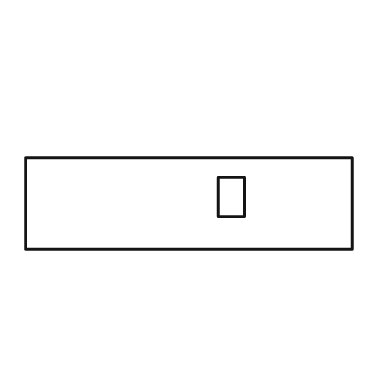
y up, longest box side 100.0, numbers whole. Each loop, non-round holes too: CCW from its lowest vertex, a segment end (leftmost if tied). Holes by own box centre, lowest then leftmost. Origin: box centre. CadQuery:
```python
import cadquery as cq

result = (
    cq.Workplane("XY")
    .moveTo(-50.0, -14.0)
    .lineTo(50.0, -14.0)
    .lineTo(50.0, 14.0)
    .lineTo(-50.0, 14.0)
    .close()
    .moveTo(9.0, -4.0)
    .lineTo(17.0, -4.0)
    .lineTo(17.0, 8.0)
    .lineTo(9.0, 8.0)
    .close()
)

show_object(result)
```